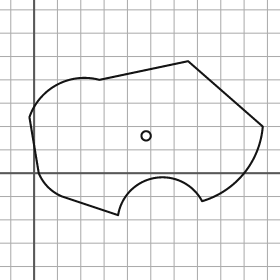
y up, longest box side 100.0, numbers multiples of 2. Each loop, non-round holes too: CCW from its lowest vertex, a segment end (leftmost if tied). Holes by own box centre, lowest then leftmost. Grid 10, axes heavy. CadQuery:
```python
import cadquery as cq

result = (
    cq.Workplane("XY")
    .moveTo(36.0, -18.0)
    .threePointArc((52.0, -2.0), (72.0, -12.0))
    .threePointArc((90.0, 0.0), (98.0, 20.0))
    .lineTo(66.0, 48.0)
    .lineTo(28.0, 40.0)
    .threePointArc((10.0, 38.0), (-2.0, 24.0))
    .lineTo(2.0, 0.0)
    .threePointArc((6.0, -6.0), (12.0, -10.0))
    .close()
    .moveTo(48.0, 16.0)
    .circle(2.0)
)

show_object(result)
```